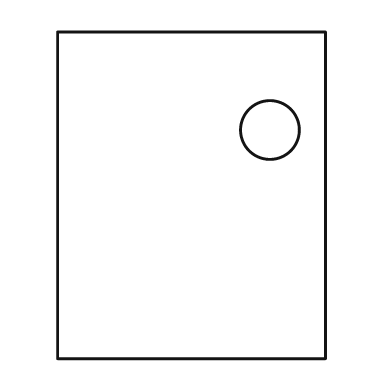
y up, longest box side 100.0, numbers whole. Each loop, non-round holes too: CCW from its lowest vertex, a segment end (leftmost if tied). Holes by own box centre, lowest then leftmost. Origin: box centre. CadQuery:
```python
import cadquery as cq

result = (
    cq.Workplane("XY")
    .moveTo(-41.0, -50.0)
    .lineTo(41.0, -50.0)
    .lineTo(41.0, 50.0)
    .lineTo(-41.0, 50.0)
    .close()
    .moveTo(24.0, 20.0)
    .circle(9.0)
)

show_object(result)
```